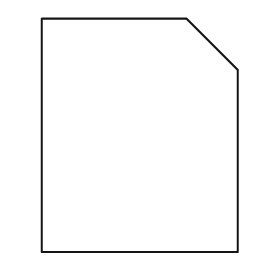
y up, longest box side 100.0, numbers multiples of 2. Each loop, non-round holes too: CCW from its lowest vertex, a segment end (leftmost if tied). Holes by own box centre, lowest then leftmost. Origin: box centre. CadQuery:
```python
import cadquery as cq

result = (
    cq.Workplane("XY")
    .moveTo(-42.0, -50.0)
    .lineTo(42.0, -50.0)
    .lineTo(42.0, 28.0)
    .lineTo(20.0, 50.0)
    .lineTo(-42.0, 50.0)
    .close()
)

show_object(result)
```